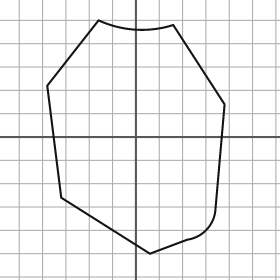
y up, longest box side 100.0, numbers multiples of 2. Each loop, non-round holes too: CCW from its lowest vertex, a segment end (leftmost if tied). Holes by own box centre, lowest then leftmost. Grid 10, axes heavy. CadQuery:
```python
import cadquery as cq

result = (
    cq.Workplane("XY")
    .moveTo(6.0, -50.0)
    .lineTo(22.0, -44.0)
    .threePointArc((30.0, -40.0), (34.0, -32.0))
    .lineTo(38.0, 14.0)
    .lineTo(16.0, 48.0)
    .threePointArc((0.0, 46.0), (-16.0, 50.0))
    .lineTo(-38.0, 22.0)
    .lineTo(-32.0, -26.0)
    .close()
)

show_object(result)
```